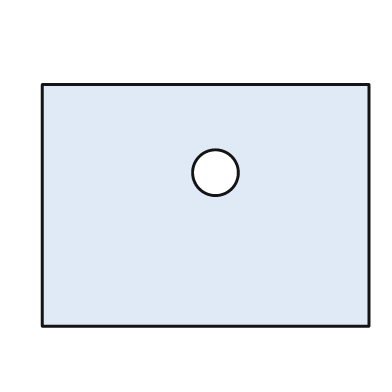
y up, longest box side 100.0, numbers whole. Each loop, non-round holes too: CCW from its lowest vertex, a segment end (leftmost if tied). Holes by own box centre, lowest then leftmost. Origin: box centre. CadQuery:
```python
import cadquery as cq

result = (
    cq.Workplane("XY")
    .moveTo(-50.0, -37.0)
    .lineTo(50.0, -37.0)
    .lineTo(50.0, 37.0)
    .lineTo(-50.0, 37.0)
    .close()
    .moveTo(3.0, 10.0)
    .circle(7.0)
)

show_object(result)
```